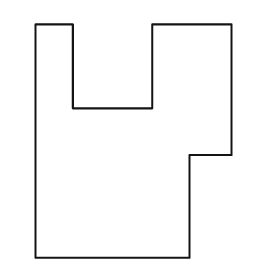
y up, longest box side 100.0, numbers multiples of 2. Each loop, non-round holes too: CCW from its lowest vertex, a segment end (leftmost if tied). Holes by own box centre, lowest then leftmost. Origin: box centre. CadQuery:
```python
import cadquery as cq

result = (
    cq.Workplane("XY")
    .moveTo(-42.0, -50.0)
    .lineTo(24.0, -50.0)
    .lineTo(24.0, -6.0)
    .lineTo(42.0, -6.0)
    .lineTo(42.0, 50.0)
    .lineTo(8.0, 50.0)
    .lineTo(8.0, 14.0)
    .lineTo(-26.0, 14.0)
    .lineTo(-26.0, 50.0)
    .lineTo(-42.0, 50.0)
    .close()
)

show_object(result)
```